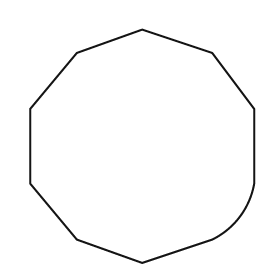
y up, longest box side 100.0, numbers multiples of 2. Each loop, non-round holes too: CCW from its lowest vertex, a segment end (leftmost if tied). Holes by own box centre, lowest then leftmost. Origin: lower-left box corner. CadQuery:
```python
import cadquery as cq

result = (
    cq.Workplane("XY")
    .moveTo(48.0, 0.0)
    .lineTo(78.0, 10.0)
    .threePointArc((90.0, 20.0), (96.0, 34.0))
    .lineTo(96.0, 66.0)
    .lineTo(78.0, 90.0)
    .lineTo(48.0, 100.0)
    .lineTo(20.0, 90.0)
    .lineTo(0.0, 66.0)
    .lineTo(0.0, 34.0)
    .lineTo(20.0, 10.0)
    .close()
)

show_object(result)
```